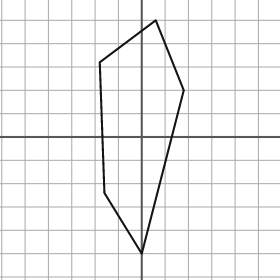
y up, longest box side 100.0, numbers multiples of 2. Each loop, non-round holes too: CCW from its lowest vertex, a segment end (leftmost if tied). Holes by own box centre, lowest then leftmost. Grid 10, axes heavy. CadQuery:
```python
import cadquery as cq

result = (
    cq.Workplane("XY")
    .moveTo(0.0, -50.0)
    .lineTo(18.0, 20.0)
    .lineTo(6.0, 50.0)
    .lineTo(-18.0, 32.0)
    .lineTo(-16.0, -24.0)
    .close()
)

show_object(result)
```